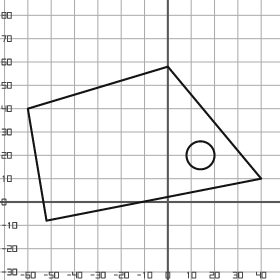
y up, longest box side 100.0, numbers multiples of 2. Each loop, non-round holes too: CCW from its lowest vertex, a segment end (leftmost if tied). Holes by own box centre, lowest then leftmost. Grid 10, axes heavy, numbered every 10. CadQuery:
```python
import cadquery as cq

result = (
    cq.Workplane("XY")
    .moveTo(-52.0, -8.0)
    .lineTo(40.0, 10.0)
    .lineTo(0.0, 58.0)
    .lineTo(-60.0, 40.0)
    .close()
    .moveTo(14.0, 20.0)
    .circle(6.0)
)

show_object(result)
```